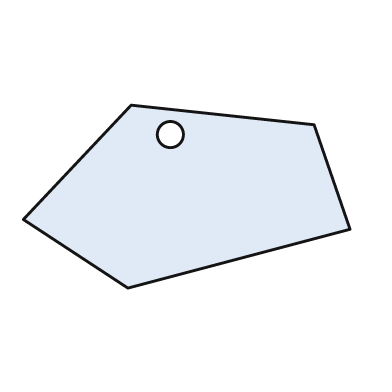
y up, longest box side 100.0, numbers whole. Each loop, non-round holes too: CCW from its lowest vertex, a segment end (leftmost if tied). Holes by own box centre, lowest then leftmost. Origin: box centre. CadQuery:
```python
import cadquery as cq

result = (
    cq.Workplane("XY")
    .moveTo(-18.0, -28.0)
    .lineTo(50.0, -10.0)
    .lineTo(39.0, 22.0)
    .lineTo(-17.0, 28.0)
    .lineTo(-50.0, -7.0)
    .close()
    .moveTo(-5.0, 19.0)
    .circle(4.0)
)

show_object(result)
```